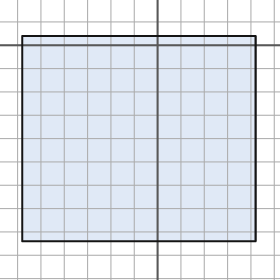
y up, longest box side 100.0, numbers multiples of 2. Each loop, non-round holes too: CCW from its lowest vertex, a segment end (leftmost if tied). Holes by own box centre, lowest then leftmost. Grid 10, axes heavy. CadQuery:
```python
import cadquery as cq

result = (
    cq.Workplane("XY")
    .moveTo(-58.0, -84.0)
    .lineTo(42.0, -84.0)
    .lineTo(42.0, 4.0)
    .lineTo(-58.0, 4.0)
    .close()
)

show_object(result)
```